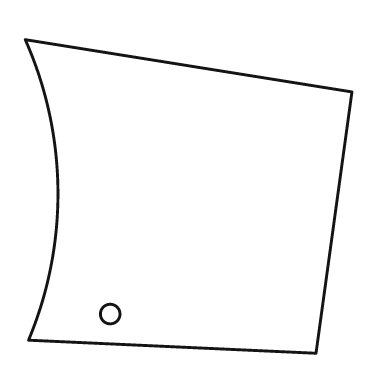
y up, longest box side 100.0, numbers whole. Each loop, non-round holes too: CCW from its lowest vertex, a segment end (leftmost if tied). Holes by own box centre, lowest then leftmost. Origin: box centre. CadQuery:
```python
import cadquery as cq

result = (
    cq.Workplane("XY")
    .moveTo(39.0, -48.0)
    .lineTo(50.0, 32.0)
    .lineTo(-50.0, 48.0)
    .threePointArc((-40.0, 2.0), (-49.0, -44.0))
    .close()
    .moveTo(-24.0, -36.0)
    .circle(3.0)
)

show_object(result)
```